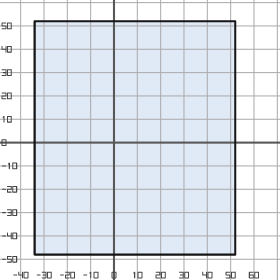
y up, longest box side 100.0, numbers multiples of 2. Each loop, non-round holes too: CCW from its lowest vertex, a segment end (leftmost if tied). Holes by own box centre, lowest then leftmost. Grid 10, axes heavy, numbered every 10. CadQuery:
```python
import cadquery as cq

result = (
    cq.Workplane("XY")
    .moveTo(-34.0, -48.0)
    .lineTo(52.0, -48.0)
    .lineTo(52.0, 52.0)
    .lineTo(-34.0, 52.0)
    .close()
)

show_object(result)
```